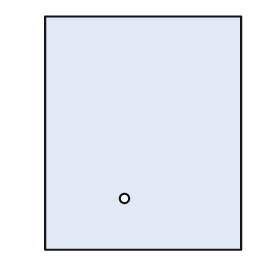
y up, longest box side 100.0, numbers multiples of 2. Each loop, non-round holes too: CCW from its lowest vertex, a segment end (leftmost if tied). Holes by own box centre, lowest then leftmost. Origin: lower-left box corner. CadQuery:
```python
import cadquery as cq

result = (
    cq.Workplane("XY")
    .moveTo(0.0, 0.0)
    .lineTo(84.0, 0.0)
    .lineTo(84.0, 100.0)
    .lineTo(0.0, 100.0)
    .close()
    .moveTo(34.0, 22.0)
    .circle(2.0)
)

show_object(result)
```